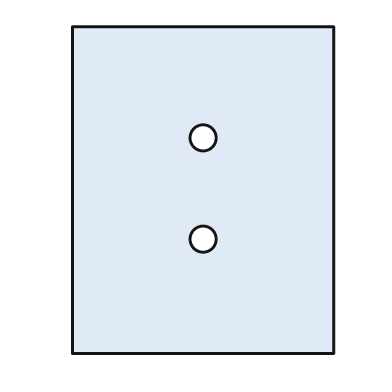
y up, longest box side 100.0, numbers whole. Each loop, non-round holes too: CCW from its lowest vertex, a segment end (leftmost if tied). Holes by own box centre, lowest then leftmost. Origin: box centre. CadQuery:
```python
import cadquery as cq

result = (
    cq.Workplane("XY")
    .moveTo(-40.0, -50.0)
    .lineTo(40.0, -50.0)
    .lineTo(40.0, 50.0)
    .lineTo(-40.0, 50.0)
    .close()
    .moveTo(0.0, -15.0)
    .circle(4.0)
    .moveTo(0.0, 16.0)
    .circle(4.0)
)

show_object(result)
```